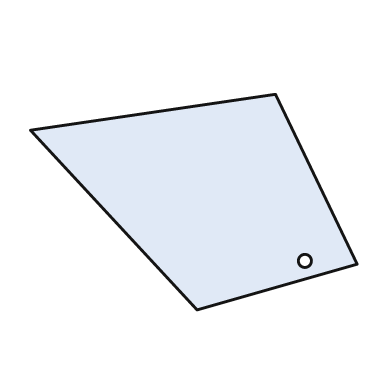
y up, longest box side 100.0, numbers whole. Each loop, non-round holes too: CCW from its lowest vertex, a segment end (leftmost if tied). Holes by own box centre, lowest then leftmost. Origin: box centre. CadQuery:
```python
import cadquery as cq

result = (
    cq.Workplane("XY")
    .moveTo(1.0, -33.0)
    .lineTo(50.0, -19.0)
    .lineTo(25.0, 33.0)
    .lineTo(-50.0, 22.0)
    .close()
    .moveTo(34.0, -18.0)
    .circle(2.0)
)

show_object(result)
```